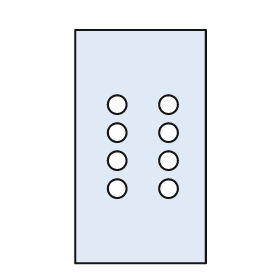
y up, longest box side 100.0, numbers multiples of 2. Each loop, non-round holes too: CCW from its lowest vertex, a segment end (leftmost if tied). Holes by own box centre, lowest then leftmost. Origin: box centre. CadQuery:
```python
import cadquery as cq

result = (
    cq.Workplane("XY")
    .moveTo(-28.0, -50.0)
    .lineTo(28.0, -50.0)
    .lineTo(28.0, 50.0)
    .lineTo(-28.0, 50.0)
    .close()
    .moveTo(-10.0, -18.0)
    .circle(4.0)
    .moveTo(12.0, -18.0)
    .circle(4.0)
    .moveTo(-10.0, -6.0)
    .circle(4.0)
    .moveTo(12.0, -6.0)
    .circle(4.0)
    .moveTo(-10.0, 6.0)
    .circle(4.0)
    .moveTo(12.0, 6.0)
    .circle(4.0)
    .moveTo(-10.0, 18.0)
    .circle(4.0)
    .moveTo(12.0, 18.0)
    .circle(4.0)
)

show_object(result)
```